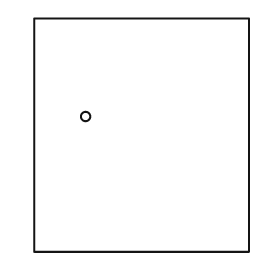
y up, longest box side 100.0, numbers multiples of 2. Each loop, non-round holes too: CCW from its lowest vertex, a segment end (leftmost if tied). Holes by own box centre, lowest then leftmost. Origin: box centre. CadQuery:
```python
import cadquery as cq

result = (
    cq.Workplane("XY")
    .moveTo(-46.0, -50.0)
    .lineTo(46.0, -50.0)
    .lineTo(46.0, 50.0)
    .lineTo(-46.0, 50.0)
    .close()
    .moveTo(-24.0, 8.0)
    .circle(2.0)
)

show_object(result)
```